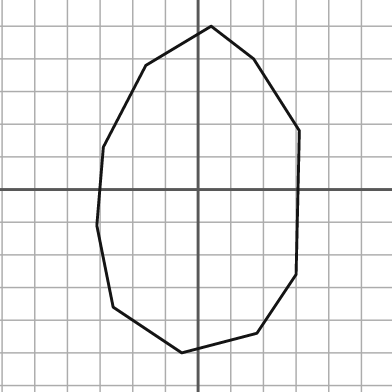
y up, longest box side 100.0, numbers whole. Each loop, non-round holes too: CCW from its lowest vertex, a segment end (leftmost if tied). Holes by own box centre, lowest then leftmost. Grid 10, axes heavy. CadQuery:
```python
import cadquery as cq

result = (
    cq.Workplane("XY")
    .moveTo(-5.0, -50.0)
    .lineTo(18.0, -44.0)
    .lineTo(30.0, -26.0)
    .lineTo(31.0, 18.0)
    .lineTo(17.0, 40.0)
    .lineTo(4.0, 50.0)
    .lineTo(-16.0, 38.0)
    .lineTo(-29.0, 13.0)
    .lineTo(-31.0, -11.0)
    .lineTo(-26.0, -36.0)
    .close()
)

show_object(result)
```